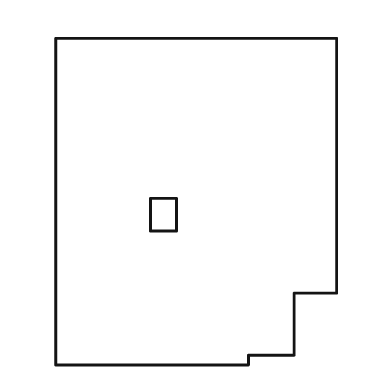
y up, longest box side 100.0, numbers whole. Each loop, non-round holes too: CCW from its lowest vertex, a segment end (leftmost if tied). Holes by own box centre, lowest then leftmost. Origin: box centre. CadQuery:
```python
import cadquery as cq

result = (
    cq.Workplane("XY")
    .moveTo(-43.0, -50.0)
    .lineTo(16.0, -50.0)
    .lineTo(16.0, -47.0)
    .lineTo(30.0, -47.0)
    .lineTo(30.0, -28.0)
    .lineTo(43.0, -28.0)
    .lineTo(43.0, 50.0)
    .lineTo(-43.0, 50.0)
    .close()
    .moveTo(-14.0, -9.0)
    .lineTo(-6.0, -9.0)
    .lineTo(-6.0, 1.0)
    .lineTo(-14.0, 1.0)
    .close()
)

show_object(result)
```